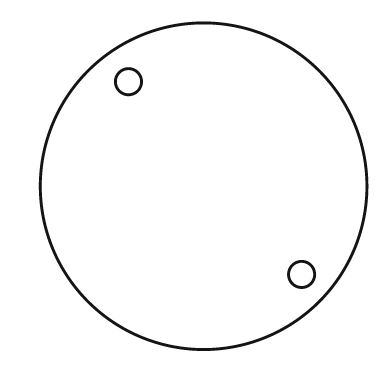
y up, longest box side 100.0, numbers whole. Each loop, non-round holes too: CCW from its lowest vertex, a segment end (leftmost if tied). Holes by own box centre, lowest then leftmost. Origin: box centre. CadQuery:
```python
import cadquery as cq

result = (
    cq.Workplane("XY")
    .moveTo(0.0, 0.0)
    .circle(50.0)
    .moveTo(30.0, -27.0)
    .circle(4.0)
    .moveTo(-23.0, 32.0)
    .circle(4.0)
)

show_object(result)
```